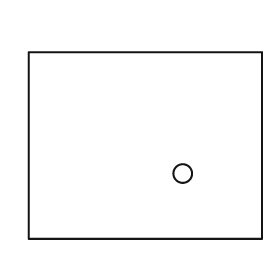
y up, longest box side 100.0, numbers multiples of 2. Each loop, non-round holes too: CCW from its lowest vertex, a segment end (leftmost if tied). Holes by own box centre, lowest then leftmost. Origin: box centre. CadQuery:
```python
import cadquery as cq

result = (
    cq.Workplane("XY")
    .moveTo(-50.0, -40.0)
    .lineTo(50.0, -40.0)
    .lineTo(50.0, 40.0)
    .lineTo(-50.0, 40.0)
    .close()
    .moveTo(16.0, -12.0)
    .circle(4.0)
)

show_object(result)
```